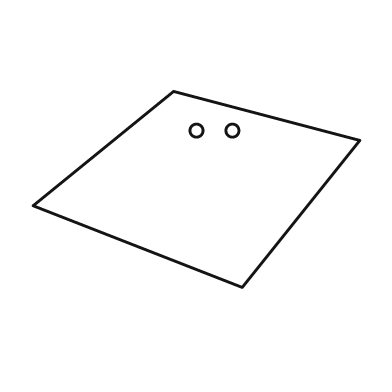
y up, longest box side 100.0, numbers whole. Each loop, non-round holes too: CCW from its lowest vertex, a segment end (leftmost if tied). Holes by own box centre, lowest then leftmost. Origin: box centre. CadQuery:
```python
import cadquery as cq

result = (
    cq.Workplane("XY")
    .moveTo(14.0, -30.0)
    .lineTo(50.0, 15.0)
    .lineTo(-7.0, 30.0)
    .lineTo(-50.0, -5.0)
    .close()
    .moveTo(0.0, 18.0)
    .circle(2.0)
    .moveTo(11.0, 18.0)
    .circle(2.0)
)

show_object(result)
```